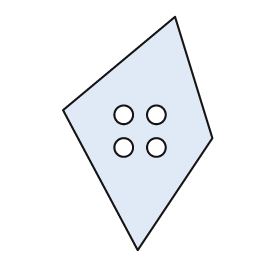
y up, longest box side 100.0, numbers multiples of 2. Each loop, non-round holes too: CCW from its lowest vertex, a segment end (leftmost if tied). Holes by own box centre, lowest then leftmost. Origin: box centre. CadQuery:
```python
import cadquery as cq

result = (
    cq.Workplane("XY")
    .moveTo(0.0, -50.0)
    .lineTo(32.0, -2.0)
    .lineTo(16.0, 50.0)
    .lineTo(-32.0, 10.0)
    .close()
    .moveTo(-6.0, -6.0)
    .circle(4.0)
    .moveTo(8.0, -6.0)
    .circle(4.0)
    .moveTo(-6.0, 8.0)
    .circle(4.0)
    .moveTo(8.0, 8.0)
    .circle(4.0)
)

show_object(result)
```